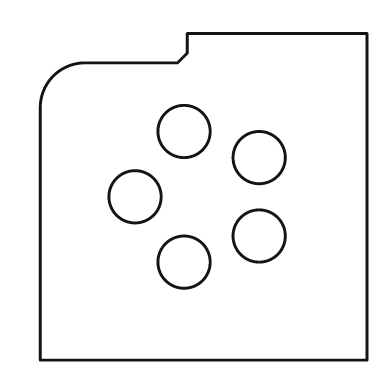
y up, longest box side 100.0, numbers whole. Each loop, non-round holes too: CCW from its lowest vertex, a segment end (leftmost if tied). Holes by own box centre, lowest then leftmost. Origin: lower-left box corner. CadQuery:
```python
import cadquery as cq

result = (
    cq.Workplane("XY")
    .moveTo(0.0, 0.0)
    .lineTo(100.0, 0.0)
    .lineTo(100.0, 100.0)
    .lineTo(45.0, 100.0)
    .lineTo(45.0, 94.0)
    .lineTo(42.0, 91.0)
    .lineTo(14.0, 91.0)
    .threePointArc((4.0, 87.0), (0.0, 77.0))
    .close()
    .moveTo(44.0, 30.0)
    .circle(8.0)
    .moveTo(67.0, 38.0)
    .circle(8.0)
    .moveTo(29.0, 50.0)
    .circle(8.0)
    .moveTo(67.0, 62.0)
    .circle(8.0)
    .moveTo(44.0, 70.0)
    .circle(8.0)
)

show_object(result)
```